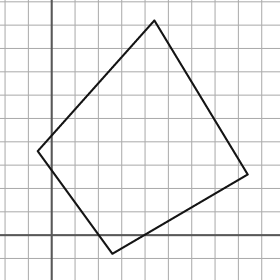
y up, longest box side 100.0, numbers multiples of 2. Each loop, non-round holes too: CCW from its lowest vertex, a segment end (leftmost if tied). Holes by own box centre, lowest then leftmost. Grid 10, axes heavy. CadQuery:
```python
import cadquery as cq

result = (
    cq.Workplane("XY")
    .moveTo(26.0, -8.0)
    .lineTo(84.0, 26.0)
    .lineTo(44.0, 92.0)
    .lineTo(-6.0, 36.0)
    .close()
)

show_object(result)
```